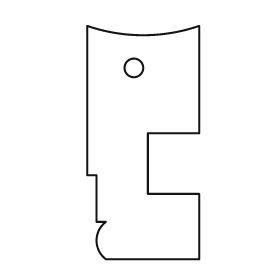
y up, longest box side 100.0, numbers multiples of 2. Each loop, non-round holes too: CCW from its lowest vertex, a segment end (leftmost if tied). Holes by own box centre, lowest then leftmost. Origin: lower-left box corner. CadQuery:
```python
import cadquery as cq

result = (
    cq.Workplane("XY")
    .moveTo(8.0, 0.0)
    .lineTo(48.0, 0.0)
    .lineTo(48.0, 28.0)
    .lineTo(26.0, 28.0)
    .lineTo(26.0, 54.0)
    .lineTo(48.0, 54.0)
    .lineTo(48.0, 100.0)
    .threePointArc((24.0, 96.0), (0.0, 100.0))
    .lineTo(0.0, 36.0)
    .lineTo(4.0, 36.0)
    .lineTo(4.0, 16.0)
    .lineTo(8.0, 16.0)
    .threePointArc((4.0, 8.0), (8.0, 0.0))
    .close()
    .moveTo(20.0, 82.0)
    .circle(4.0)
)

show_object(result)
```